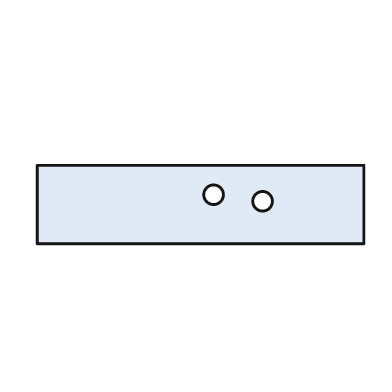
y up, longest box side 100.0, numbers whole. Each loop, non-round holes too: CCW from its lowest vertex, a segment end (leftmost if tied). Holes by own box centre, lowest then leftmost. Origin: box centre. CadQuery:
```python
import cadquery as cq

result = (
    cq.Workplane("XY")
    .moveTo(-50.0, -12.0)
    .lineTo(50.0, -12.0)
    .lineTo(50.0, 12.0)
    .lineTo(-50.0, 12.0)
    .close()
    .moveTo(19.0, 1.0)
    .circle(3.0)
    .moveTo(4.0, 3.0)
    .circle(3.0)
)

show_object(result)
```